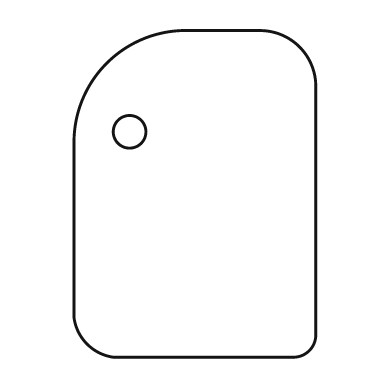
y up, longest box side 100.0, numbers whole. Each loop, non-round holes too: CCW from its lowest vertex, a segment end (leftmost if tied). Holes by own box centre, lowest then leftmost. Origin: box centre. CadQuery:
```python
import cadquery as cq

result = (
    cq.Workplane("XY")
    .moveTo(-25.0, -50.0)
    .lineTo(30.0, -50.0)
    .threePointArc((35.0, -48.0), (37.0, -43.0))
    .lineTo(37.0, 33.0)
    .threePointArc((32.0, 45.0), (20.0, 50.0))
    .lineTo(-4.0, 50.0)
    .threePointArc((-27.0, 40.0), (-37.0, 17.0))
    .lineTo(-37.0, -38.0)
    .threePointArc((-33.0, -46.0), (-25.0, -50.0))
    .close()
    .moveTo(-20.0, 19.0)
    .circle(5.0)
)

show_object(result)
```